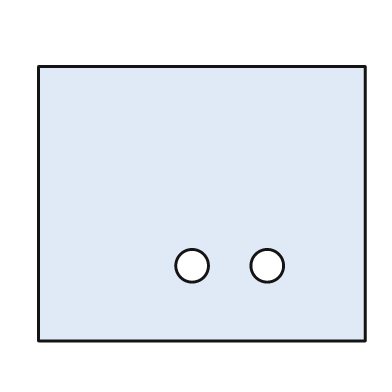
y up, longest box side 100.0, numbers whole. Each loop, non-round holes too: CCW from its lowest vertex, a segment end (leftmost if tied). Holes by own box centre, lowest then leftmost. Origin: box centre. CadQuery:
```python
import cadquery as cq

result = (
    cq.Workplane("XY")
    .moveTo(-50.0, -42.0)
    .lineTo(50.0, -42.0)
    .lineTo(50.0, 42.0)
    .lineTo(-50.0, 42.0)
    .close()
    .moveTo(-3.0, -19.0)
    .circle(5.0)
    .moveTo(20.0, -19.0)
    .circle(5.0)
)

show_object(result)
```